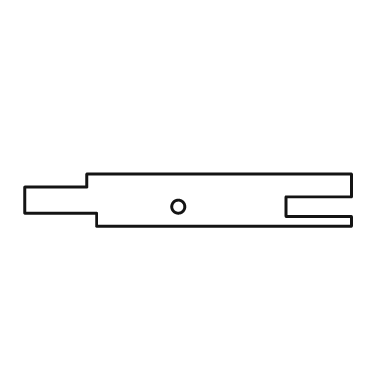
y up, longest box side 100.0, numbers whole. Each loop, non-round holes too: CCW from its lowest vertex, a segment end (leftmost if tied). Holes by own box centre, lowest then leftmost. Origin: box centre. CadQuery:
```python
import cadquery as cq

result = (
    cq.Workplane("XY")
    .moveTo(-28.0, -8.0)
    .lineTo(50.0, -8.0)
    .lineTo(50.0, -5.0)
    .lineTo(30.0, -5.0)
    .lineTo(30.0, 1.0)
    .lineTo(50.0, 1.0)
    .lineTo(50.0, 8.0)
    .lineTo(-31.0, 8.0)
    .lineTo(-31.0, 4.0)
    .lineTo(-50.0, 4.0)
    .lineTo(-50.0, -4.0)
    .lineTo(-28.0, -4.0)
    .close()
    .moveTo(-3.0, -2.0)
    .circle(2.0)
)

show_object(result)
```